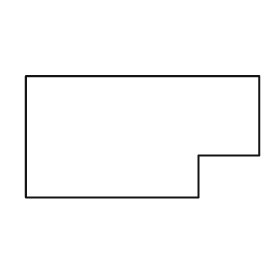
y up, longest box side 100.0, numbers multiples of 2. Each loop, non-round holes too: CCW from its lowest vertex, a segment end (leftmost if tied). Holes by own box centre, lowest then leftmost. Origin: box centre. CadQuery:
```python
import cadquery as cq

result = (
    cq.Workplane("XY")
    .moveTo(-50.0, -26.0)
    .lineTo(24.0, -26.0)
    .lineTo(24.0, -8.0)
    .lineTo(50.0, -8.0)
    .lineTo(50.0, 26.0)
    .lineTo(-50.0, 26.0)
    .close()
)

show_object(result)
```